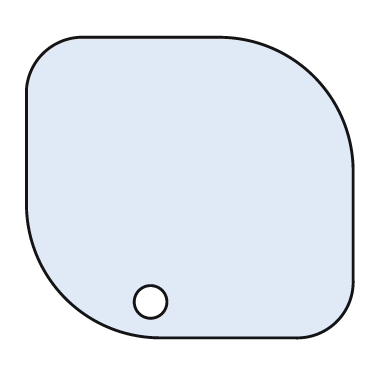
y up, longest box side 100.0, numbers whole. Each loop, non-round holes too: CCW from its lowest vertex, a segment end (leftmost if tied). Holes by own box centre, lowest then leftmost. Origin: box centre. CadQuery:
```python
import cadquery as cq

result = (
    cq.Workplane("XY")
    .moveTo(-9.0, -46.0)
    .lineTo(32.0, -46.0)
    .threePointArc((45.0, -41.0), (50.0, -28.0))
    .lineTo(50.0, 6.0)
    .threePointArc((38.0, 34.0), (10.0, 46.0))
    .lineTo(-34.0, 46.0)
    .threePointArc((-45.0, 41.0), (-50.0, 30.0))
    .lineTo(-50.0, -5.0)
    .threePointArc((-38.0, -34.0), (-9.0, -46.0))
    .close()
    .moveTo(-12.0, -35.0)
    .circle(5.0)
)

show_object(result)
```